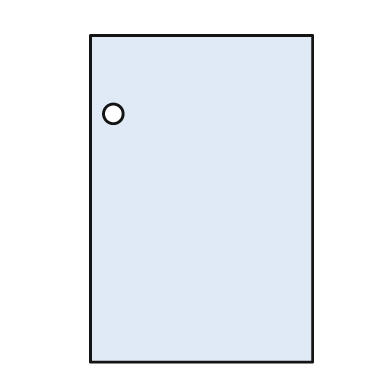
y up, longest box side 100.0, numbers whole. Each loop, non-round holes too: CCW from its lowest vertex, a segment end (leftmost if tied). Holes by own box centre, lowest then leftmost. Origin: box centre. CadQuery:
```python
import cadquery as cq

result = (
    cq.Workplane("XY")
    .moveTo(-34.0, -50.0)
    .lineTo(34.0, -50.0)
    .lineTo(34.0, 50.0)
    .lineTo(-34.0, 50.0)
    .close()
    .moveTo(-27.0, 26.0)
    .circle(3.0)
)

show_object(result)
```